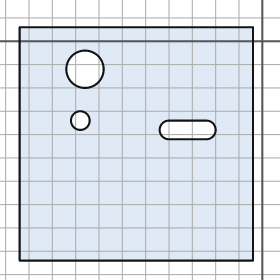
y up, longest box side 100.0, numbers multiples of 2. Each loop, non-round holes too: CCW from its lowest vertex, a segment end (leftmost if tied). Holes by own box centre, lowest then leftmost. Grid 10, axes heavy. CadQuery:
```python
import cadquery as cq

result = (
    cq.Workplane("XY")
    .moveTo(-104.0, -94.0)
    .lineTo(-4.0, -94.0)
    .lineTo(-4.0, 6.0)
    .lineTo(-104.0, 6.0)
    .close()
    .moveTo(-40.0, -42.0)
    .lineTo(-24.0, -42.0)
    .threePointArc((-20.0, -38.0), (-24.0, -34.0))
    .lineTo(-40.0, -34.0)
    .threePointArc((-44.0, -38.0), (-40.0, -42.0))
    .close()
    .moveTo(-78.0, -34.0)
    .circle(4.0)
    .moveTo(-76.0, -12.0)
    .circle(8.0)
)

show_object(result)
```